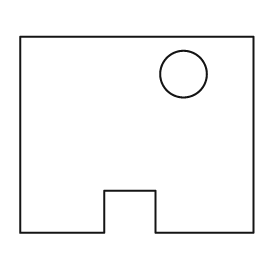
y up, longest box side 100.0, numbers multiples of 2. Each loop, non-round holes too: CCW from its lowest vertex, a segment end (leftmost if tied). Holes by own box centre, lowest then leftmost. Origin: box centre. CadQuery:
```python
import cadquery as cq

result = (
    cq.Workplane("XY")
    .moveTo(-50.0, -42.0)
    .lineTo(-14.0, -42.0)
    .lineTo(-14.0, -24.0)
    .lineTo(8.0, -24.0)
    .lineTo(8.0, -42.0)
    .lineTo(50.0, -42.0)
    .lineTo(50.0, 42.0)
    .lineTo(-50.0, 42.0)
    .close()
    .moveTo(20.0, 26.0)
    .circle(10.0)
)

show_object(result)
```